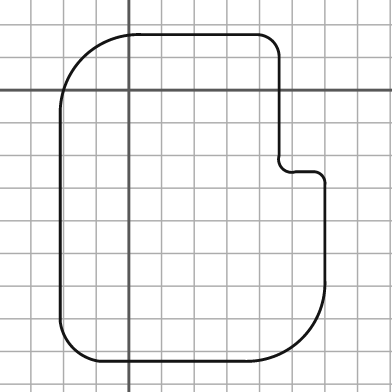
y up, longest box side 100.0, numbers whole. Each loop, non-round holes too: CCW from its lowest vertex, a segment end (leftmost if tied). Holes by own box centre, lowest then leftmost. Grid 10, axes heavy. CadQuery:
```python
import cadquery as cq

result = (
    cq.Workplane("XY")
    .moveTo(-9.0, -83.0)
    .lineTo(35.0, -83.0)
    .threePointArc((53.0, -76.0), (60.0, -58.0))
    .lineTo(60.0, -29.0)
    .threePointArc((59.0, -26.0), (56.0, -25.0))
    .lineTo(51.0, -25.0)
    .threePointArc((47.0, -24.0), (46.0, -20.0))
    .lineTo(46.0, 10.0)
    .threePointArc((44.0, 15.0), (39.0, 17.0))
    .lineTo(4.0, 17.0)
    .threePointArc((-14.0, 10.0), (-21.0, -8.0))
    .lineTo(-21.0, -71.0)
    .threePointArc((-17.0, -79.0), (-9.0, -83.0))
    .close()
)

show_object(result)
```